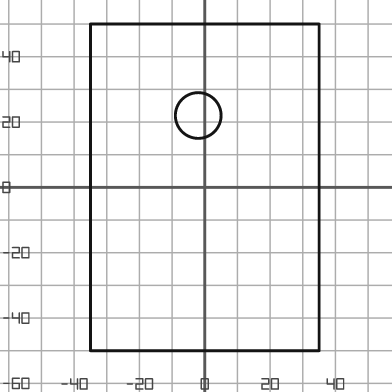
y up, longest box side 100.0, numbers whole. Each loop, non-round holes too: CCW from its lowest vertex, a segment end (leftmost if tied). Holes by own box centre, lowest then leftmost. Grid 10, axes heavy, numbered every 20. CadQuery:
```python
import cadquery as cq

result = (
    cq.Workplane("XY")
    .moveTo(-35.0, -50.0)
    .lineTo(35.0, -50.0)
    .lineTo(35.0, 50.0)
    .lineTo(-35.0, 50.0)
    .close()
    .moveTo(-2.0, 22.0)
    .circle(7.0)
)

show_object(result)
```